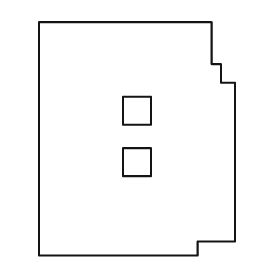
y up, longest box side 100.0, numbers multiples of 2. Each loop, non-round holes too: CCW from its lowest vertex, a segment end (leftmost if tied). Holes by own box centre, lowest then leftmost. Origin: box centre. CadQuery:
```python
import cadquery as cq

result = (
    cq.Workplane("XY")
    .moveTo(-42.0, -50.0)
    .lineTo(26.0, -50.0)
    .lineTo(26.0, -44.0)
    .lineTo(42.0, -44.0)
    .lineTo(42.0, 24.0)
    .lineTo(36.0, 24.0)
    .lineTo(36.0, 32.0)
    .lineTo(32.0, 32.0)
    .lineTo(32.0, 50.0)
    .lineTo(-42.0, 50.0)
    .close()
    .moveTo(-6.0, -16.0)
    .lineTo(6.0, -16.0)
    .lineTo(6.0, -4.0)
    .lineTo(-6.0, -4.0)
    .close()
    .moveTo(-6.0, 6.0)
    .lineTo(6.0, 6.0)
    .lineTo(6.0, 18.0)
    .lineTo(-6.0, 18.0)
    .close()
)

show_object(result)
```